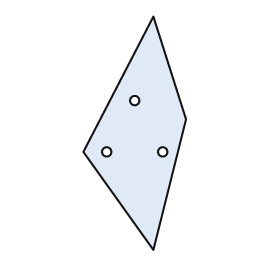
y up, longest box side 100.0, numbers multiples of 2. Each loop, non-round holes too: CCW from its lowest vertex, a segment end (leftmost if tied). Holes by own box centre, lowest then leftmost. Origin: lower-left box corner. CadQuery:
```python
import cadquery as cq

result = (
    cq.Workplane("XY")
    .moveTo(30.0, 0.0)
    .lineTo(44.0, 56.0)
    .lineTo(30.0, 100.0)
    .lineTo(0.0, 42.0)
    .close()
    .moveTo(10.0, 42.0)
    .circle(2.0)
    .moveTo(34.0, 42.0)
    .circle(2.0)
    .moveTo(22.0, 64.0)
    .circle(2.0)
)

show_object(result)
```